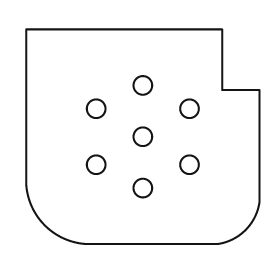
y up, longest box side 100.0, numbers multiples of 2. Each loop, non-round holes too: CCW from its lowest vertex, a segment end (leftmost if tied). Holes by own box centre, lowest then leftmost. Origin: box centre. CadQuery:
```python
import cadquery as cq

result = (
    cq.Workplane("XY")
    .moveTo(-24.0, -46.0)
    .lineTo(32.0, -46.0)
    .threePointArc((44.0, -40.0), (50.0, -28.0))
    .lineTo(50.0, 20.0)
    .lineTo(34.0, 20.0)
    .lineTo(34.0, 46.0)
    .lineTo(-50.0, 46.0)
    .lineTo(-50.0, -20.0)
    .threePointArc((-42.0, -38.0), (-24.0, -46.0))
    .close()
    .moveTo(0.0, -22.0)
    .circle(4.0)
    .moveTo(-20.0, -12.0)
    .circle(4.0)
    .moveTo(20.0, -12.0)
    .circle(4.0)
    .moveTo(0.0, 0.0)
    .circle(4.0)
    .moveTo(-20.0, 12.0)
    .circle(4.0)
    .moveTo(20.0, 12.0)
    .circle(4.0)
    .moveTo(0.0, 22.0)
    .circle(4.0)
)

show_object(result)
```